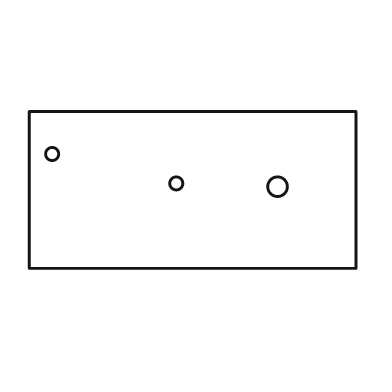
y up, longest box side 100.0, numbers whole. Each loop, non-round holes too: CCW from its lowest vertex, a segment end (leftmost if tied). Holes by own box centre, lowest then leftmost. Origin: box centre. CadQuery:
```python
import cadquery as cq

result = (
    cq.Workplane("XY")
    .moveTo(-50.0, -24.0)
    .lineTo(50.0, -24.0)
    .lineTo(50.0, 24.0)
    .lineTo(-50.0, 24.0)
    .close()
    .moveTo(26.0, 1.0)
    .circle(3.0)
    .moveTo(-5.0, 2.0)
    .circle(2.0)
    .moveTo(-43.0, 11.0)
    .circle(2.0)
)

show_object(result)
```